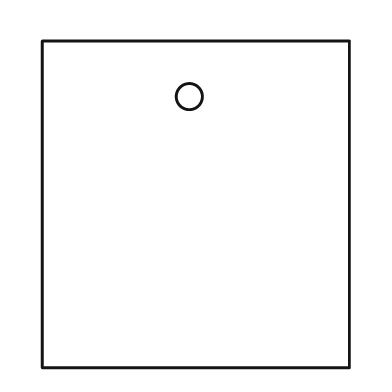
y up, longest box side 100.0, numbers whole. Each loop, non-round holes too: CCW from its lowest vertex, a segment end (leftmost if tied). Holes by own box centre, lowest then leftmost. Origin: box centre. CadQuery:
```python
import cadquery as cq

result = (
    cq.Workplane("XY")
    .moveTo(-47.0, -50.0)
    .lineTo(47.0, -50.0)
    .lineTo(47.0, 50.0)
    .lineTo(-47.0, 50.0)
    .close()
    .moveTo(-2.0, 33.0)
    .circle(4.0)
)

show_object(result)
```